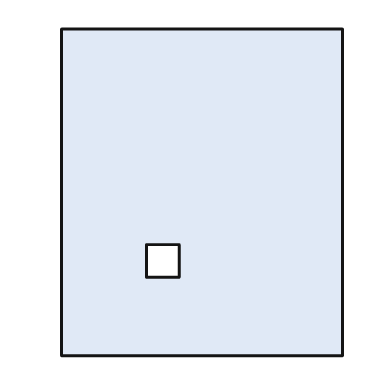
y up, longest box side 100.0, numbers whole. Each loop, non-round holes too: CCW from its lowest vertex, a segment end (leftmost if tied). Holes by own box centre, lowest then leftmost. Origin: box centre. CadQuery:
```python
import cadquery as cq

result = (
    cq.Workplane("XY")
    .moveTo(-43.0, -50.0)
    .lineTo(43.0, -50.0)
    .lineTo(43.0, 50.0)
    .lineTo(-43.0, 50.0)
    .close()
    .moveTo(-17.0, -26.0)
    .lineTo(-7.0, -26.0)
    .lineTo(-7.0, -16.0)
    .lineTo(-17.0, -16.0)
    .close()
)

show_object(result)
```